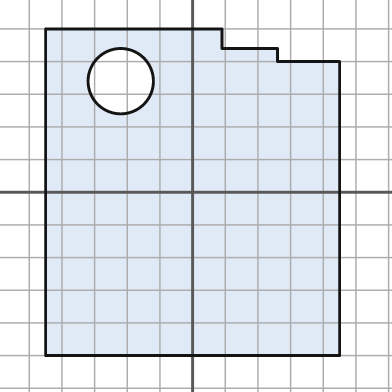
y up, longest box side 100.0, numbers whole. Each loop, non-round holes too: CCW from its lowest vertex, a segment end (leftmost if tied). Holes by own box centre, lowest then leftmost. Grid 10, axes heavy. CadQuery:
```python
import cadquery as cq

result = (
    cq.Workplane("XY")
    .moveTo(-45.0, -50.0)
    .lineTo(45.0, -50.0)
    .lineTo(45.0, 40.0)
    .lineTo(26.0, 40.0)
    .lineTo(26.0, 44.0)
    .lineTo(9.0, 44.0)
    .lineTo(9.0, 50.0)
    .lineTo(-45.0, 50.0)
    .close()
    .moveTo(-22.0, 34.0)
    .circle(10.0)
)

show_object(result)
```